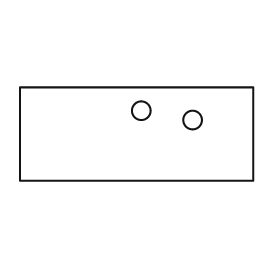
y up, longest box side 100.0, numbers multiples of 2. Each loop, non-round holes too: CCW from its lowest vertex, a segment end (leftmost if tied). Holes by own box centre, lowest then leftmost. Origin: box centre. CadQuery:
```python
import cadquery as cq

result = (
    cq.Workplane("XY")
    .moveTo(-50.0, -20.0)
    .lineTo(50.0, -20.0)
    .lineTo(50.0, 20.0)
    .lineTo(-50.0, 20.0)
    .close()
    .moveTo(24.0, 6.0)
    .circle(4.0)
    .moveTo(2.0, 10.0)
    .circle(4.0)
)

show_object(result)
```